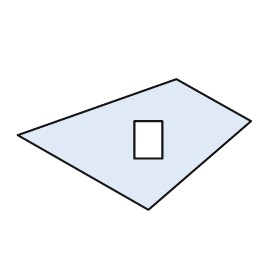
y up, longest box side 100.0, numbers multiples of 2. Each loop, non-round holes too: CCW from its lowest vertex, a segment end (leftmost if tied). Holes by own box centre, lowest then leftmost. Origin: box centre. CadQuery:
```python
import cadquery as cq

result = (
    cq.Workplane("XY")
    .moveTo(6.0, -28.0)
    .lineTo(50.0, 10.0)
    .lineTo(18.0, 28.0)
    .lineTo(-50.0, 4.0)
    .close()
    .moveTo(0.0, -6.0)
    .lineTo(12.0, -6.0)
    .lineTo(12.0, 10.0)
    .lineTo(0.0, 10.0)
    .close()
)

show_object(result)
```